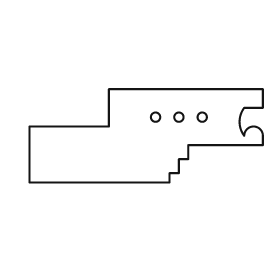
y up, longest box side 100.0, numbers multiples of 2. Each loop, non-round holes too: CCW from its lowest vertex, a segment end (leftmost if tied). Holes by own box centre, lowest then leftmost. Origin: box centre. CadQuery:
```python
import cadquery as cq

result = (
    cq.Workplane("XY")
    .moveTo(-50.0, -20.0)
    .lineTo(10.0, -20.0)
    .lineTo(10.0, -16.0)
    .lineTo(14.0, -16.0)
    .lineTo(14.0, -10.0)
    .lineTo(18.0, -10.0)
    .lineTo(18.0, -4.0)
    .lineTo(50.0, -4.0)
    .lineTo(50.0, 0.0)
    .threePointArc((46.0, 4.0), (42.0, 0.0))
    .threePointArc((40.0, 6.0), (42.0, 12.0))
    .lineTo(50.0, 12.0)
    .lineTo(50.0, 20.0)
    .lineTo(-16.0, 20.0)
    .lineTo(-16.0, 4.0)
    .lineTo(-50.0, 4.0)
    .close()
    .moveTo(4.0, 8.0)
    .circle(2.0)
    .moveTo(14.0, 8.0)
    .circle(2.0)
    .moveTo(24.0, 8.0)
    .circle(2.0)
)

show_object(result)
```